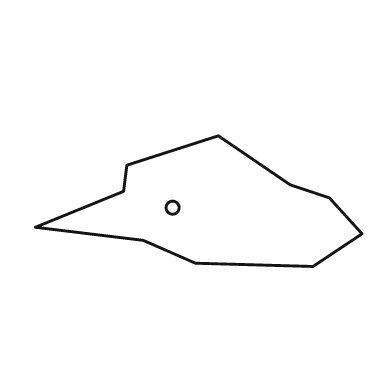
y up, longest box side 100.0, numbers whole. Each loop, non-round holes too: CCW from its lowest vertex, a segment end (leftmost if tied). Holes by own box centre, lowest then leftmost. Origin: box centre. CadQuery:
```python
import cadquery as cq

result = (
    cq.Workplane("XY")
    .moveTo(35.0, -20.0)
    .lineTo(50.0, -10.0)
    .lineTo(40.0, 1.0)
    .lineTo(28.0, 5.0)
    .lineTo(6.0, 20.0)
    .lineTo(-22.0, 11.0)
    .lineTo(-23.0, 3.0)
    .lineTo(-50.0, -8.0)
    .lineTo(-17.0, -12.0)
    .lineTo(-1.0, -19.0)
    .close()
    .moveTo(-8.0, -2.0)
    .circle(2.0)
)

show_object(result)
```